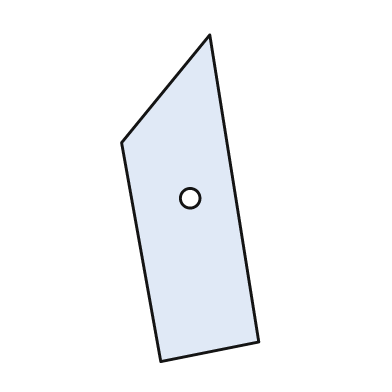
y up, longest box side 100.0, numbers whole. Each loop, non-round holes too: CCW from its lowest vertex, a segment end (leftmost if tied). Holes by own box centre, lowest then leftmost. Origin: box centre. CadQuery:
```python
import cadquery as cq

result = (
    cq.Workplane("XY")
    .moveTo(-9.0, -50.0)
    .lineTo(21.0, -44.0)
    .lineTo(6.0, 50.0)
    .lineTo(-21.0, 17.0)
    .close()
    .moveTo(0.0, 0.0)
    .circle(3.0)
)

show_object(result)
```